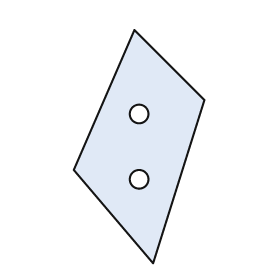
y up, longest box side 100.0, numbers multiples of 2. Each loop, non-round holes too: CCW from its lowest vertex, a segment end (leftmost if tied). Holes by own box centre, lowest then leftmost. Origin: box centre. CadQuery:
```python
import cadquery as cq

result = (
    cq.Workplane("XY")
    .moveTo(6.0, -50.0)
    .lineTo(28.0, 20.0)
    .lineTo(-2.0, 50.0)
    .lineTo(-28.0, -10.0)
    .close()
    .moveTo(0.0, -14.0)
    .circle(4.0)
    .moveTo(0.0, 14.0)
    .circle(4.0)
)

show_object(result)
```